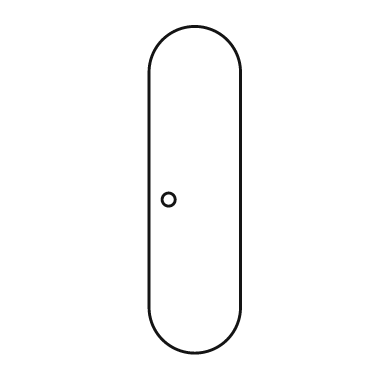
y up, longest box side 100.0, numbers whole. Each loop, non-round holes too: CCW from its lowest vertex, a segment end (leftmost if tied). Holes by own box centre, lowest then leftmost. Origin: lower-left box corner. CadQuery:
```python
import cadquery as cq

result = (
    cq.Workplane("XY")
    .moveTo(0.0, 14.0)
    .threePointArc((14.0, 0.0), (28.0, 14.0))
    .lineTo(28.0, 86.0)
    .threePointArc((14.0, 100.0), (0.0, 86.0))
    .close()
    .moveTo(6.0, 47.0)
    .circle(2.0)
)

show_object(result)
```